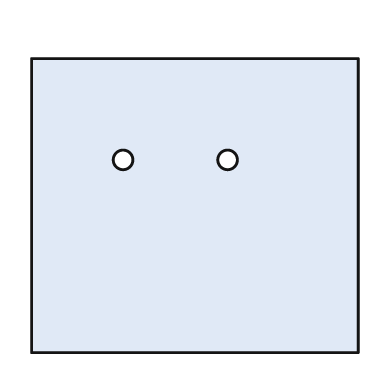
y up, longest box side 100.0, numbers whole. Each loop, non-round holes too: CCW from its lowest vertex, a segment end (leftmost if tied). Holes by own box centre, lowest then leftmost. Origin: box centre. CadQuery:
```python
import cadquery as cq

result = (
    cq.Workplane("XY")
    .moveTo(-50.0, -45.0)
    .lineTo(50.0, -45.0)
    .lineTo(50.0, 45.0)
    .lineTo(-50.0, 45.0)
    .close()
    .moveTo(-22.0, 14.0)
    .circle(3.0)
    .moveTo(10.0, 14.0)
    .circle(3.0)
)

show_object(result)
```